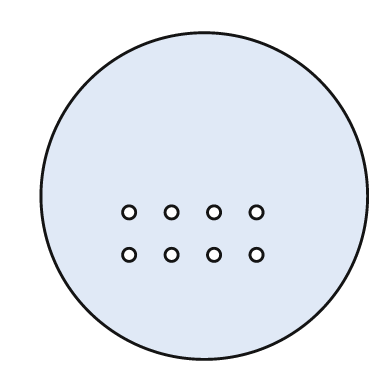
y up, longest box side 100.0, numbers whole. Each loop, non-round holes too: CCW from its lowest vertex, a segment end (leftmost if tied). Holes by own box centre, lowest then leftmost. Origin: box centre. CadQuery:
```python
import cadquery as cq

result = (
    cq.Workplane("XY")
    .moveTo(0.0, 0.0)
    .circle(50.0)
    .moveTo(-23.0, -18.0)
    .circle(2.0)
    .moveTo(-10.0, -18.0)
    .circle(2.0)
    .moveTo(3.0, -18.0)
    .circle(2.0)
    .moveTo(16.0, -18.0)
    .circle(2.0)
    .moveTo(-23.0, -5.0)
    .circle(2.0)
    .moveTo(-10.0, -5.0)
    .circle(2.0)
    .moveTo(3.0, -5.0)
    .circle(2.0)
    .moveTo(16.0, -5.0)
    .circle(2.0)
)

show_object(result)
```